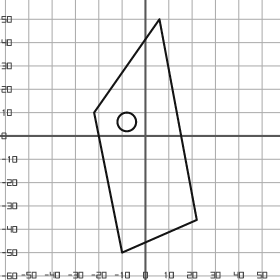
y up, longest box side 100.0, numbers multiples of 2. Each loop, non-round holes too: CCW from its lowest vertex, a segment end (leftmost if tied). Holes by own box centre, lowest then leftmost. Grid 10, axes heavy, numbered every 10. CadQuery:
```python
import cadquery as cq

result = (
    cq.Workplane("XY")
    .moveTo(-10.0, -50.0)
    .lineTo(22.0, -36.0)
    .lineTo(6.0, 50.0)
    .lineTo(-22.0, 10.0)
    .close()
    .moveTo(-8.0, 6.0)
    .circle(4.0)
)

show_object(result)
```